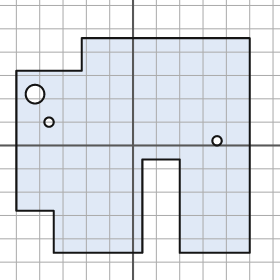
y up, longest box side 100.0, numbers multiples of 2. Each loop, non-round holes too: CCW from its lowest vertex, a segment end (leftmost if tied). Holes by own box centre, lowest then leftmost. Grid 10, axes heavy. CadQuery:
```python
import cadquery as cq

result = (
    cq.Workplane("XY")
    .moveTo(-34.0, -46.0)
    .lineTo(4.0, -46.0)
    .lineTo(4.0, -6.0)
    .lineTo(20.0, -6.0)
    .lineTo(20.0, -46.0)
    .lineTo(50.0, -46.0)
    .lineTo(50.0, 46.0)
    .lineTo(-22.0, 46.0)
    .lineTo(-22.0, 32.0)
    .lineTo(-50.0, 32.0)
    .lineTo(-50.0, -28.0)
    .lineTo(-34.0, -28.0)
    .close()
    .moveTo(36.0, 2.0)
    .circle(2.0)
    .moveTo(-36.0, 10.0)
    .circle(2.0)
    .moveTo(-42.0, 22.0)
    .circle(4.0)
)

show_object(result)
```